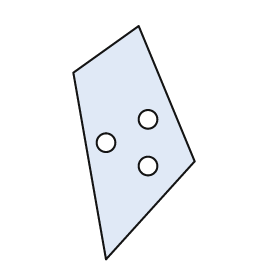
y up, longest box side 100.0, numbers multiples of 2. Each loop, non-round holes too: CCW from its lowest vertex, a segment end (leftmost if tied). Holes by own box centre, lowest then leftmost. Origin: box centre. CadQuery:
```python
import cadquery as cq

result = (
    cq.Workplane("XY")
    .moveTo(-12.0, -50.0)
    .lineTo(26.0, -8.0)
    .lineTo(2.0, 50.0)
    .lineTo(-26.0, 30.0)
    .close()
    .moveTo(6.0, -10.0)
    .circle(4.0)
    .moveTo(-12.0, 0.0)
    .circle(4.0)
    .moveTo(6.0, 10.0)
    .circle(4.0)
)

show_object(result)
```